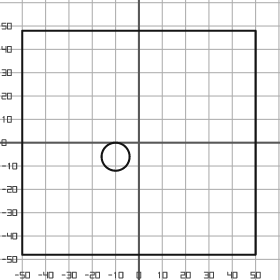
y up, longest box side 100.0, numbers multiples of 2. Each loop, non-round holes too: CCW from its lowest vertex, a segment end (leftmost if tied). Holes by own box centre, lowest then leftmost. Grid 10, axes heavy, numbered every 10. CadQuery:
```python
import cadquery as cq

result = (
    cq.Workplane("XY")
    .moveTo(-50.0, -48.0)
    .lineTo(50.0, -48.0)
    .lineTo(50.0, 48.0)
    .lineTo(-50.0, 48.0)
    .close()
    .moveTo(-10.0, -6.0)
    .circle(6.0)
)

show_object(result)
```